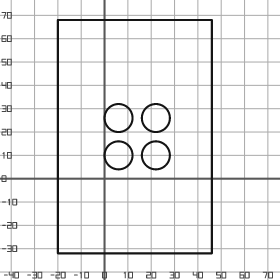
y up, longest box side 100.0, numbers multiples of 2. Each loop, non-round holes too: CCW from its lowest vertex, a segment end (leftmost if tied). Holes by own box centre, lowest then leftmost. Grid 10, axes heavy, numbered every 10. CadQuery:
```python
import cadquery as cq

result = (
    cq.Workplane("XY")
    .moveTo(-20.0, -32.0)
    .lineTo(46.0, -32.0)
    .lineTo(46.0, 68.0)
    .lineTo(-20.0, 68.0)
    .close()
    .moveTo(6.0, 10.0)
    .circle(6.0)
    .moveTo(22.0, 10.0)
    .circle(6.0)
    .moveTo(6.0, 26.0)
    .circle(6.0)
    .moveTo(22.0, 26.0)
    .circle(6.0)
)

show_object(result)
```